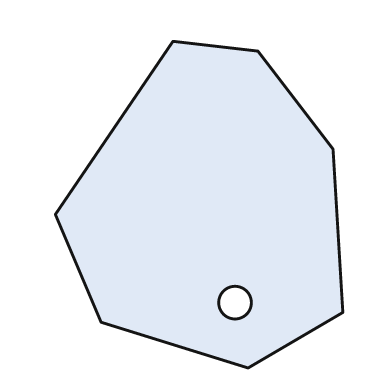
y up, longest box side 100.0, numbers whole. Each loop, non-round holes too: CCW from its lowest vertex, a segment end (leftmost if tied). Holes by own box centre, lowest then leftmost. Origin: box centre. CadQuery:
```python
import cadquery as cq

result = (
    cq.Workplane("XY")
    .moveTo(15.0, -50.0)
    .lineTo(44.0, -33.0)
    .lineTo(41.0, 17.0)
    .lineTo(18.0, 47.0)
    .lineTo(-8.0, 50.0)
    .lineTo(-44.0, -3.0)
    .lineTo(-30.0, -36.0)
    .close()
    .moveTo(11.0, -30.0)
    .circle(5.0)
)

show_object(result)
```